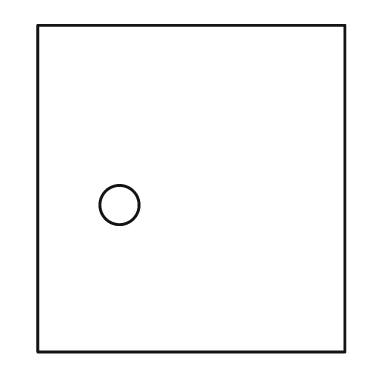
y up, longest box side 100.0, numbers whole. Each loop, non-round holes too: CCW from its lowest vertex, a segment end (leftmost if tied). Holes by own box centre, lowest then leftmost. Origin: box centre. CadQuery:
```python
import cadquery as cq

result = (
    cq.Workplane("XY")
    .moveTo(-47.0, -50.0)
    .lineTo(47.0, -50.0)
    .lineTo(47.0, 50.0)
    .lineTo(-47.0, 50.0)
    .close()
    .moveTo(-22.0, -5.0)
    .circle(6.0)
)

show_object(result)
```